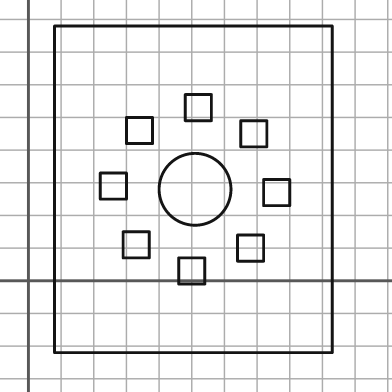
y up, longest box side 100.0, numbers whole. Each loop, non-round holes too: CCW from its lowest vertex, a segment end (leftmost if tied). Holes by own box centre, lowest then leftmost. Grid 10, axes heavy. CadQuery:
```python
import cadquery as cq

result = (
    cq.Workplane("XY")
    .moveTo(8.0, -22.0)
    .lineTo(93.0, -22.0)
    .lineTo(93.0, 78.0)
    .lineTo(8.0, 78.0)
    .close()
    .moveTo(46.0, -1.0)
    .lineTo(54.0, -1.0)
    .lineTo(54.0, 7.0)
    .lineTo(46.0, 7.0)
    .close()
    .moveTo(64.0, 6.0)
    .lineTo(72.0, 6.0)
    .lineTo(72.0, 14.0)
    .lineTo(64.0, 14.0)
    .close()
    .moveTo(29.0, 7.0)
    .lineTo(37.0, 7.0)
    .lineTo(37.0, 15.0)
    .lineTo(29.0, 15.0)
    .close()
    .moveTo(72.0, 23.0)
    .lineTo(80.0, 23.0)
    .lineTo(80.0, 31.0)
    .lineTo(72.0, 31.0)
    .close()
    .moveTo(51.0, 28.0)
    .circle(11.0)
    .moveTo(22.0, 25.0)
    .lineTo(30.0, 25.0)
    .lineTo(30.0, 33.0)
    .lineTo(22.0, 33.0)
    .close()
    .moveTo(65.0, 41.0)
    .lineTo(73.0, 41.0)
    .lineTo(73.0, 49.0)
    .lineTo(65.0, 49.0)
    .close()
    .moveTo(30.0, 42.0)
    .lineTo(38.0, 42.0)
    .lineTo(38.0, 50.0)
    .lineTo(30.0, 50.0)
    .close()
    .moveTo(48.0, 49.0)
    .lineTo(56.0, 49.0)
    .lineTo(56.0, 57.0)
    .lineTo(48.0, 57.0)
    .close()
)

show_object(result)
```